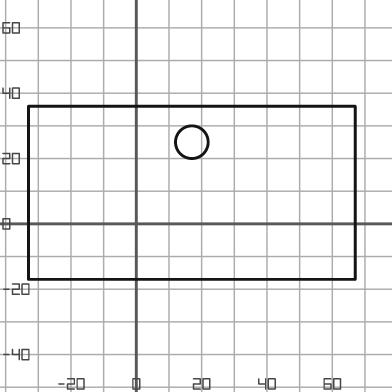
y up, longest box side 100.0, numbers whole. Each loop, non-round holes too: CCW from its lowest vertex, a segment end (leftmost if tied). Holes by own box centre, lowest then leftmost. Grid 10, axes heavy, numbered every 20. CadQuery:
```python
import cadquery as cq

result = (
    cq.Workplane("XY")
    .moveTo(-33.0, -17.0)
    .lineTo(67.0, -17.0)
    .lineTo(67.0, 36.0)
    .lineTo(-33.0, 36.0)
    .close()
    .moveTo(17.0, 25.0)
    .circle(5.0)
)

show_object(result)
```